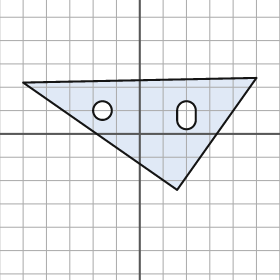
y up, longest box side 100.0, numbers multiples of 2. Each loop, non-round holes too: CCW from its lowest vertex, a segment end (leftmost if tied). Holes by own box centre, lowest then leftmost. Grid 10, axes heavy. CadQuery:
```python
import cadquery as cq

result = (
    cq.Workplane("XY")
    .moveTo(16.0, -24.0)
    .lineTo(50.0, 24.0)
    .lineTo(-50.0, 22.0)
    .close()
    .moveTo(16.0, 6.0)
    .threePointArc((20.0, 2.0), (24.0, 6.0))
    .lineTo(24.0, 10.0)
    .threePointArc((20.0, 14.0), (16.0, 10.0))
    .close()
    .moveTo(-16.0, 10.0)
    .circle(4.0)
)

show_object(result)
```